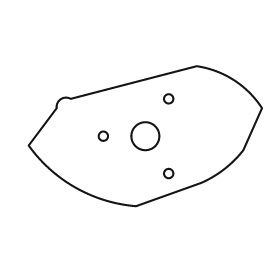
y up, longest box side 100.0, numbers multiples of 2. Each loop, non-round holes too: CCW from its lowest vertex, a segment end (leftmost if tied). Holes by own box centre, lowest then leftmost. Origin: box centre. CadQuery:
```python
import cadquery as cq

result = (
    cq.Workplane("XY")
    .moveTo(-4.0, -30.0)
    .lineTo(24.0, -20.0)
    .threePointArc((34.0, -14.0), (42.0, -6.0))
    .lineTo(50.0, 12.0)
    .threePointArc((38.0, 24.0), (22.0, 30.0))
    .lineTo(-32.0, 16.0)
    .threePointArc((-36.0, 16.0), (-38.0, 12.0))
    .lineTo(-50.0, -4.0)
    .threePointArc((-30.0, -22.0), (-4.0, -30.0))
    .close()
    .moveTo(10.0, -16.0)
    .circle(2.0)
    .moveTo(-18.0, 0.0)
    .circle(2.0)
    .moveTo(0.0, 0.0)
    .circle(6.0)
    .moveTo(10.0, 16.0)
    .circle(2.0)
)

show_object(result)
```